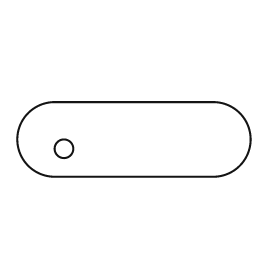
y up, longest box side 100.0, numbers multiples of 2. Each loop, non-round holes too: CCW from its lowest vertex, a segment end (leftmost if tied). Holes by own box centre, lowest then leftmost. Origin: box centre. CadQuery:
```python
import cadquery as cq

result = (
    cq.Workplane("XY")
    .moveTo(-34.0, -16.0)
    .lineTo(34.0, -16.0)
    .threePointArc((50.0, 0.0), (34.0, 16.0))
    .lineTo(-34.0, 16.0)
    .threePointArc((-50.0, 0.0), (-34.0, -16.0))
    .close()
    .moveTo(-30.0, -4.0)
    .circle(4.0)
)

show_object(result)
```